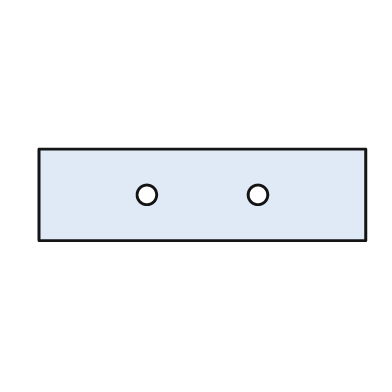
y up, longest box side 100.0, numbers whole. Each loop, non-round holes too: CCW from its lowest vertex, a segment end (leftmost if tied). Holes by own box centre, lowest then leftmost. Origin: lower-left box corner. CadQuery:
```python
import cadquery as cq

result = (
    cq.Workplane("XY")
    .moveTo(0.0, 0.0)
    .lineTo(100.0, 0.0)
    .lineTo(100.0, 28.0)
    .lineTo(0.0, 28.0)
    .close()
    .moveTo(33.0, 14.0)
    .circle(3.0)
    .moveTo(67.0, 14.0)
    .circle(3.0)
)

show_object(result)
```